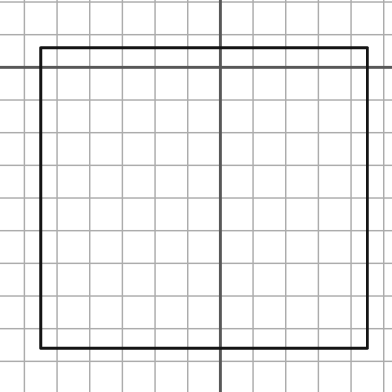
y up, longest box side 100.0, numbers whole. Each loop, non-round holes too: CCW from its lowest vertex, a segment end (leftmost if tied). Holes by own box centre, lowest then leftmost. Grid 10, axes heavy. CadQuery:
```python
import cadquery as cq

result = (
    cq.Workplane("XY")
    .moveTo(-55.0, -86.0)
    .lineTo(45.0, -86.0)
    .lineTo(45.0, 6.0)
    .lineTo(-55.0, 6.0)
    .close()
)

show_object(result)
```